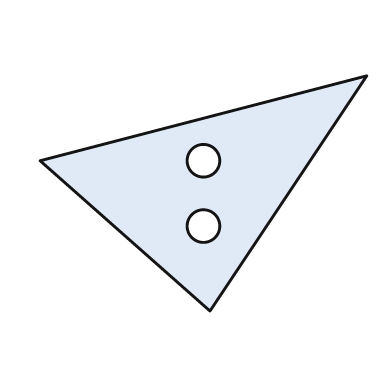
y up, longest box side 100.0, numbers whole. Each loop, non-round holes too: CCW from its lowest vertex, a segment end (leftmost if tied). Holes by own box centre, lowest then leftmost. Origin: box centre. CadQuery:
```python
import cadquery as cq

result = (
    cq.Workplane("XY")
    .moveTo(2.0, -36.0)
    .lineTo(50.0, 36.0)
    .lineTo(-50.0, 10.0)
    .close()
    .moveTo(0.0, -10.0)
    .circle(5.0)
    .moveTo(0.0, 10.0)
    .circle(5.0)
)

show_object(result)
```